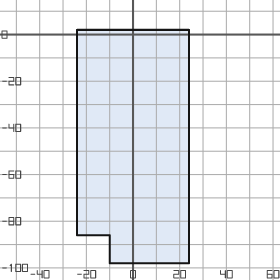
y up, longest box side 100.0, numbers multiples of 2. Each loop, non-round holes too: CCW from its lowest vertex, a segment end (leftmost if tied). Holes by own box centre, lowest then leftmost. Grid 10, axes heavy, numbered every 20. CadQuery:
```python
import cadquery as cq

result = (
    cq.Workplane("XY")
    .moveTo(-10.0, -98.0)
    .lineTo(24.0, -98.0)
    .lineTo(24.0, 2.0)
    .lineTo(-24.0, 2.0)
    .lineTo(-24.0, -86.0)
    .lineTo(-10.0, -86.0)
    .close()
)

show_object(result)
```